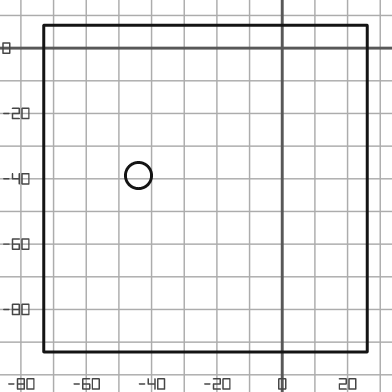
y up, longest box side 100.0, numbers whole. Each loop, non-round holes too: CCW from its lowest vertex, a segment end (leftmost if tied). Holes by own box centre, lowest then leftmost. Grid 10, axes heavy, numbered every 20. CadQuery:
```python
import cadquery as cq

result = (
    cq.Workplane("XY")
    .moveTo(-73.0, -93.0)
    .lineTo(26.0, -93.0)
    .lineTo(26.0, 7.0)
    .lineTo(-73.0, 7.0)
    .close()
    .moveTo(-44.0, -39.0)
    .circle(4.0)
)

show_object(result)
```